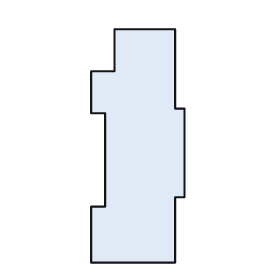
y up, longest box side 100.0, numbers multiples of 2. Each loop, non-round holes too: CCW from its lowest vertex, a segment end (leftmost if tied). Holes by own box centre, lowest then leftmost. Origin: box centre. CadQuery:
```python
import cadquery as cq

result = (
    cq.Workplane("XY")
    .moveTo(-20.0, -50.0)
    .lineTo(16.0, -50.0)
    .lineTo(16.0, -22.0)
    .lineTo(20.0, -22.0)
    .lineTo(20.0, 16.0)
    .lineTo(16.0, 16.0)
    .lineTo(16.0, 50.0)
    .lineTo(-10.0, 50.0)
    .lineTo(-10.0, 32.0)
    .lineTo(-20.0, 32.0)
    .lineTo(-20.0, 14.0)
    .lineTo(-14.0, 14.0)
    .lineTo(-14.0, -26.0)
    .lineTo(-20.0, -26.0)
    .close()
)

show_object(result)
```